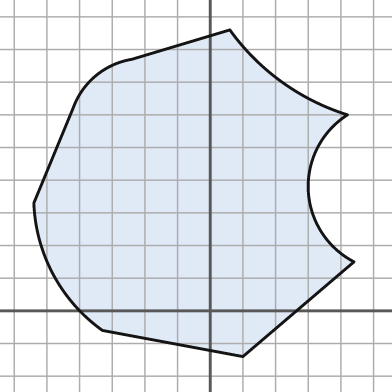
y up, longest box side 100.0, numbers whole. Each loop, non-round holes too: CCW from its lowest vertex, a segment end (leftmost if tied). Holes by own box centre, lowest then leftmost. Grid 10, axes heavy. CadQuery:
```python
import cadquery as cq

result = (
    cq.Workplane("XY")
    .moveTo(10.0, -14.0)
    .lineTo(44.0, 15.0)
    .threePointArc((30.0, 37.0), (42.0, 60.0))
    .threePointArc((22.0, 70.0), (6.0, 86.0))
    .lineTo(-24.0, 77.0)
    .threePointArc((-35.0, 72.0), (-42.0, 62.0))
    .lineTo(-54.0, 33.0)
    .threePointArc((-48.0, 11.0), (-33.0, -6.0))
    .close()
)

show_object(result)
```